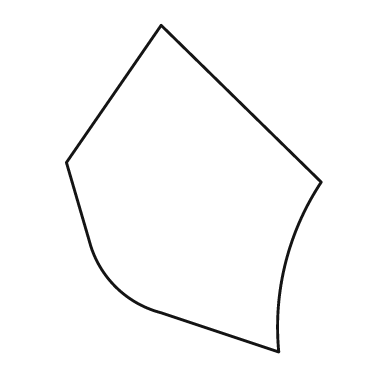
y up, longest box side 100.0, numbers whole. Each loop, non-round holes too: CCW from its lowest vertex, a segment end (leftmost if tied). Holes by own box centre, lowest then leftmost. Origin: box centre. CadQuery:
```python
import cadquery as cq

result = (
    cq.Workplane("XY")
    .moveTo(26.0, -50.0)
    .threePointArc((28.0, -23.0), (39.0, 2.0))
    .lineTo(-10.0, 50.0)
    .lineTo(-39.0, 8.0)
    .lineTo(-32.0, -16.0)
    .threePointArc((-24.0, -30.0), (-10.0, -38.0))
    .close()
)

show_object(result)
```